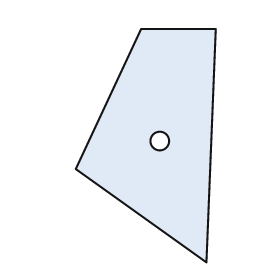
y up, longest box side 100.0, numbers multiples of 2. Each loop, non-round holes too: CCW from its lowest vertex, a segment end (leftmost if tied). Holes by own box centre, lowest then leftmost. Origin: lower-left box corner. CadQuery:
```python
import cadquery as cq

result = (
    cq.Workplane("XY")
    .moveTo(56.0, 0.0)
    .lineTo(60.0, 100.0)
    .lineTo(28.0, 100.0)
    .lineTo(0.0, 40.0)
    .close()
    .moveTo(36.0, 52.0)
    .circle(4.0)
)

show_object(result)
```